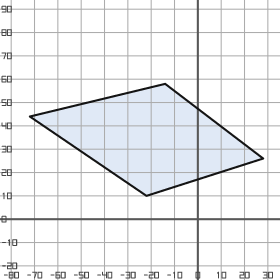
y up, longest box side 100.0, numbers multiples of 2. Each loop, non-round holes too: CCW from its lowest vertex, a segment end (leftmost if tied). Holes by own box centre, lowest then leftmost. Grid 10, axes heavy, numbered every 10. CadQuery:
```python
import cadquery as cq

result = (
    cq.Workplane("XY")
    .moveTo(-22.0, 10.0)
    .lineTo(28.0, 26.0)
    .lineTo(-14.0, 58.0)
    .lineTo(-72.0, 44.0)
    .close()
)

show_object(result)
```